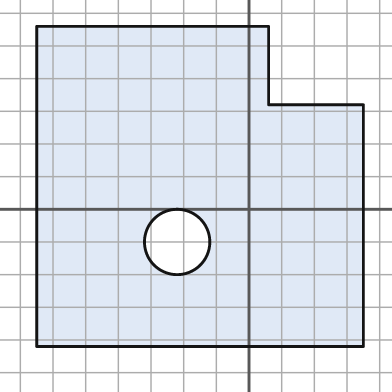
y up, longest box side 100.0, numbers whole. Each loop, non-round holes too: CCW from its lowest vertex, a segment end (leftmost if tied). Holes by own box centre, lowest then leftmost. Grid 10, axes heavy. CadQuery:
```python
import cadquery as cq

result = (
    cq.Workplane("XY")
    .moveTo(-65.0, -42.0)
    .lineTo(35.0, -42.0)
    .lineTo(35.0, 32.0)
    .lineTo(6.0, 32.0)
    .lineTo(6.0, 56.0)
    .lineTo(-65.0, 56.0)
    .close()
    .moveTo(-22.0, -10.0)
    .circle(10.0)
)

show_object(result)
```